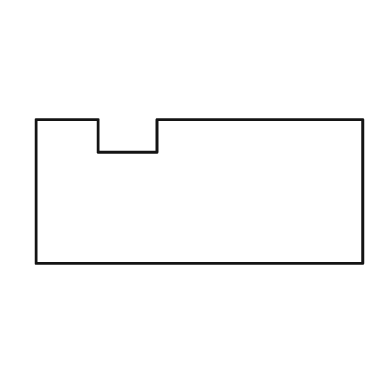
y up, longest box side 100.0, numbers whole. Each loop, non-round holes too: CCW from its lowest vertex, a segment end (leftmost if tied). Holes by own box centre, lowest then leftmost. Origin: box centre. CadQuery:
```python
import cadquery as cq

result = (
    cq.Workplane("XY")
    .moveTo(-50.0, -22.0)
    .lineTo(50.0, -22.0)
    .lineTo(50.0, 22.0)
    .lineTo(-13.0, 22.0)
    .lineTo(-13.0, 12.0)
    .lineTo(-31.0, 12.0)
    .lineTo(-31.0, 22.0)
    .lineTo(-50.0, 22.0)
    .close()
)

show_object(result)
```